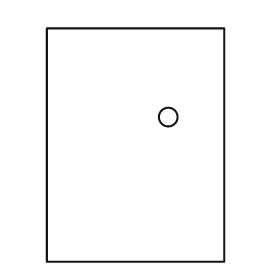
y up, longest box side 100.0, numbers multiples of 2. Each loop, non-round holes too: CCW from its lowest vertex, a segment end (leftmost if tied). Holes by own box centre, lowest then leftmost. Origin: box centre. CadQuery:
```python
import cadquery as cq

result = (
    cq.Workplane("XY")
    .moveTo(-38.0, -50.0)
    .lineTo(38.0, -50.0)
    .lineTo(38.0, 50.0)
    .lineTo(-38.0, 50.0)
    .close()
    .moveTo(14.0, 12.0)
    .circle(4.0)
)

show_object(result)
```